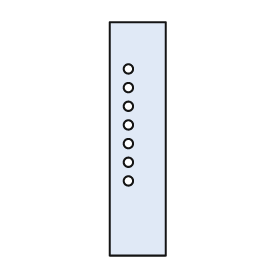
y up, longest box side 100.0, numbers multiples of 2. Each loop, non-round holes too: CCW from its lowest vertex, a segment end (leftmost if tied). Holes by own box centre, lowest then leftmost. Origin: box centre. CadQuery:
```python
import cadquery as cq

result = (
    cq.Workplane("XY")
    .moveTo(-12.0, -50.0)
    .lineTo(12.0, -50.0)
    .lineTo(12.0, 50.0)
    .lineTo(-12.0, 50.0)
    .close()
    .moveTo(-4.0, -18.0)
    .circle(2.0)
    .moveTo(-4.0, -10.0)
    .circle(2.0)
    .moveTo(-4.0, -2.0)
    .circle(2.0)
    .moveTo(-4.0, 6.0)
    .circle(2.0)
    .moveTo(-4.0, 14.0)
    .circle(2.0)
    .moveTo(-4.0, 22.0)
    .circle(2.0)
    .moveTo(-4.0, 30.0)
    .circle(2.0)
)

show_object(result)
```